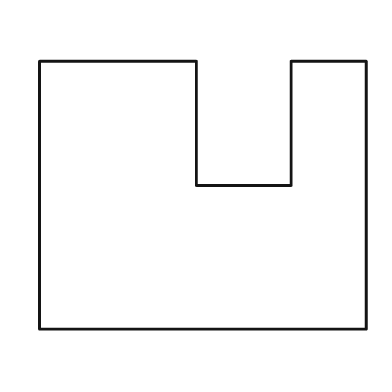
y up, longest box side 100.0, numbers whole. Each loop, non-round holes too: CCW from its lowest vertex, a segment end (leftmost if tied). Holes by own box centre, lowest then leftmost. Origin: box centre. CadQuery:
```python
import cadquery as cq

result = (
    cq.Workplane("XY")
    .moveTo(-50.0, -41.0)
    .lineTo(50.0, -41.0)
    .lineTo(50.0, 41.0)
    .lineTo(27.0, 41.0)
    .lineTo(27.0, 3.0)
    .lineTo(-2.0, 3.0)
    .lineTo(-2.0, 41.0)
    .lineTo(-50.0, 41.0)
    .close()
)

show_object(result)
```